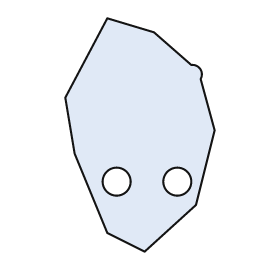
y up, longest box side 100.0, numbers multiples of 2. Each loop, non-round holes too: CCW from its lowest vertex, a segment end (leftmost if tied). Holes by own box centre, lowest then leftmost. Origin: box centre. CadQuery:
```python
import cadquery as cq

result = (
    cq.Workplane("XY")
    .moveTo(2.0, -50.0)
    .lineTo(24.0, -30.0)
    .lineTo(32.0, 2.0)
    .lineTo(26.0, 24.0)
    .threePointArc((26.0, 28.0), (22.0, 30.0))
    .lineTo(6.0, 44.0)
    .lineTo(-14.0, 50.0)
    .lineTo(-32.0, 16.0)
    .lineTo(-28.0, -8.0)
    .lineTo(-14.0, -42.0)
    .close()
    .moveTo(-10.0, -20.0)
    .circle(6.0)
    .moveTo(16.0, -20.0)
    .circle(6.0)
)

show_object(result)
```